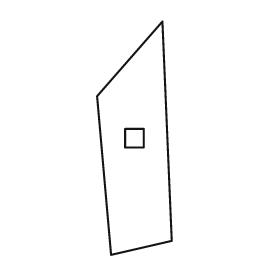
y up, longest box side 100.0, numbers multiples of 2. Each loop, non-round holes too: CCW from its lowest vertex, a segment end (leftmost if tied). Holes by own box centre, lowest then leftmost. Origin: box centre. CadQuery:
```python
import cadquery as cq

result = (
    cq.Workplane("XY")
    .moveTo(-10.0, -50.0)
    .lineTo(16.0, -44.0)
    .lineTo(12.0, 50.0)
    .lineTo(-16.0, 18.0)
    .close()
    .moveTo(-4.0, -4.0)
    .lineTo(4.0, -4.0)
    .lineTo(4.0, 4.0)
    .lineTo(-4.0, 4.0)
    .close()
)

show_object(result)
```